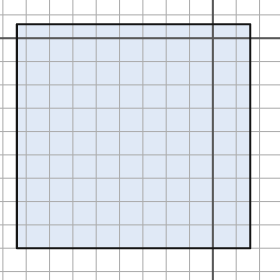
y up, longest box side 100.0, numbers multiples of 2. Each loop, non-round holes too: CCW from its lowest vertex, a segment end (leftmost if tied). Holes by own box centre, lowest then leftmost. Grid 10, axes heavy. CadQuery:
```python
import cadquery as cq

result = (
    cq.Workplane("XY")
    .moveTo(-84.0, -90.0)
    .lineTo(16.0, -90.0)
    .lineTo(16.0, 6.0)
    .lineTo(-84.0, 6.0)
    .close()
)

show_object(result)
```